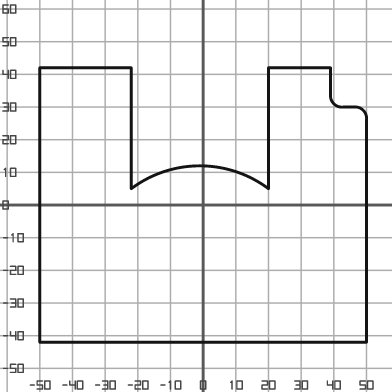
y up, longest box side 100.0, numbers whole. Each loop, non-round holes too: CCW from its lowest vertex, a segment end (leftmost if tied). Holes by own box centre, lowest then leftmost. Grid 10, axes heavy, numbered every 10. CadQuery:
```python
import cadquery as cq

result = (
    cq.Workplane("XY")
    .moveTo(-50.0, -42.0)
    .lineTo(50.0, -42.0)
    .lineTo(50.0, 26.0)
    .threePointArc((49.0, 29.0), (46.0, 30.0))
    .lineTo(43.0, 30.0)
    .threePointArc((40.0, 31.0), (39.0, 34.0))
    .lineTo(39.0, 42.0)
    .lineTo(20.0, 42.0)
    .lineTo(20.0, 5.0)
    .threePointArc((-1.0, 12.0), (-22.0, 5.0))
    .lineTo(-22.0, 42.0)
    .lineTo(-50.0, 42.0)
    .close()
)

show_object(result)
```